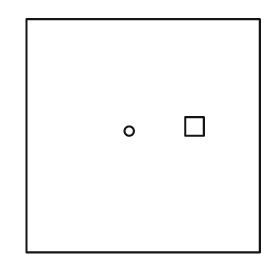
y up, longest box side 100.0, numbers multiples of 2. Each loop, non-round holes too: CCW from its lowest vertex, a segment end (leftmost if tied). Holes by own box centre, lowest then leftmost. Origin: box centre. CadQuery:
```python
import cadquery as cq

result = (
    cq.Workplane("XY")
    .moveTo(-50.0, -50.0)
    .lineTo(50.0, -50.0)
    .lineTo(50.0, 50.0)
    .lineTo(-50.0, 50.0)
    .close()
    .moveTo(-6.0, 2.0)
    .circle(2.0)
    .moveTo(18.0, 0.0)
    .lineTo(26.0, 0.0)
    .lineTo(26.0, 8.0)
    .lineTo(18.0, 8.0)
    .close()
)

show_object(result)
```